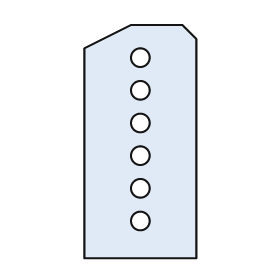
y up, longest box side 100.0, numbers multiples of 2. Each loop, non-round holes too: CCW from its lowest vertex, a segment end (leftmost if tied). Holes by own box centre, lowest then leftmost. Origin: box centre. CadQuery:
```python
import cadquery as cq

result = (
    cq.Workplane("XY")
    .moveTo(-24.0, -50.0)
    .lineTo(24.0, -50.0)
    .lineTo(24.0, 44.0)
    .lineTo(18.0, 50.0)
    .lineTo(-4.0, 50.0)
    .lineTo(-24.0, 40.0)
    .close()
    .moveTo(0.0, -34.0)
    .circle(4.0)
    .moveTo(0.0, -20.0)
    .circle(4.0)
    .moveTo(0.0, -6.0)
    .circle(4.0)
    .moveTo(0.0, 8.0)
    .circle(4.0)
    .moveTo(0.0, 22.0)
    .circle(4.0)
    .moveTo(0.0, 36.0)
    .circle(4.0)
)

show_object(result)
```